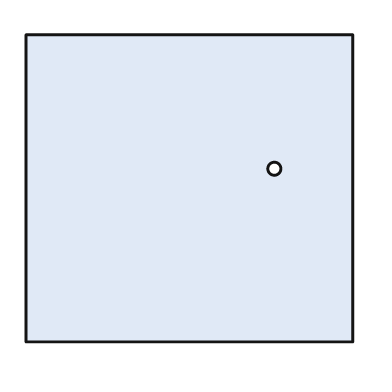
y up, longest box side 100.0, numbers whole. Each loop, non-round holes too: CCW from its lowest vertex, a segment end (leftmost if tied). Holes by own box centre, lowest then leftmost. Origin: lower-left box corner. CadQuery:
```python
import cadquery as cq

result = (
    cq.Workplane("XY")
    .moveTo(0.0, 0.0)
    .lineTo(100.0, 0.0)
    .lineTo(100.0, 94.0)
    .lineTo(0.0, 94.0)
    .close()
    .moveTo(76.0, 53.0)
    .circle(2.0)
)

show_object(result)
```